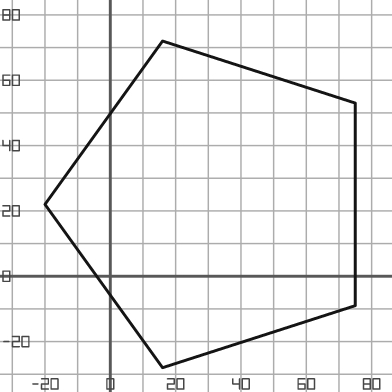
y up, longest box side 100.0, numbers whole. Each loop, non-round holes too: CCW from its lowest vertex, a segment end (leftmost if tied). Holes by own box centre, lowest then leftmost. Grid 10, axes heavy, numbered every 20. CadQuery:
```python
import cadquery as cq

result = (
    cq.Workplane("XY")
    .moveTo(16.0, -28.0)
    .lineTo(75.0, -9.0)
    .lineTo(75.0, 53.0)
    .lineTo(16.0, 72.0)
    .lineTo(-20.0, 22.0)
    .close()
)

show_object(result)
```